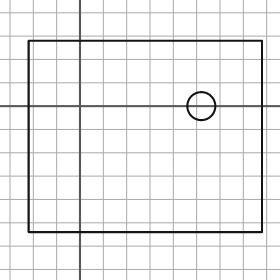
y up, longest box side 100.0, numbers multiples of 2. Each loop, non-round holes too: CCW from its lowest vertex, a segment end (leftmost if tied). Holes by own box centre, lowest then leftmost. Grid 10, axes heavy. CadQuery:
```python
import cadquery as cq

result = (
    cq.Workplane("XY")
    .moveTo(-22.0, -54.0)
    .lineTo(78.0, -54.0)
    .lineTo(78.0, 28.0)
    .lineTo(-22.0, 28.0)
    .close()
    .moveTo(52.0, 0.0)
    .circle(6.0)
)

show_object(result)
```